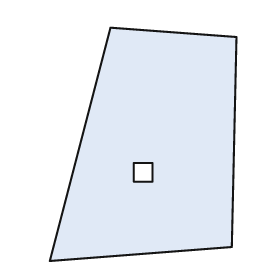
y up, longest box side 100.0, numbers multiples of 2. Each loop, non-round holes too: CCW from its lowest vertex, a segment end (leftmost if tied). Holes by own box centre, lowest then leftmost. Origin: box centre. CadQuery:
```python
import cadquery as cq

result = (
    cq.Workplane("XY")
    .moveTo(-40.0, -50.0)
    .lineTo(38.0, -44.0)
    .lineTo(40.0, 46.0)
    .lineTo(-14.0, 50.0)
    .close()
    .moveTo(-4.0, -16.0)
    .lineTo(4.0, -16.0)
    .lineTo(4.0, -8.0)
    .lineTo(-4.0, -8.0)
    .close()
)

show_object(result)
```